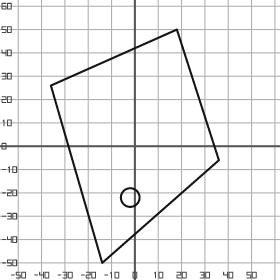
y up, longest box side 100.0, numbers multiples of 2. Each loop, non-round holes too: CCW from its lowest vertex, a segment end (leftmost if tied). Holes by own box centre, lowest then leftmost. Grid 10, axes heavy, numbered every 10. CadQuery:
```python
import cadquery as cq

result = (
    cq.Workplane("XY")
    .moveTo(-14.0, -50.0)
    .lineTo(36.0, -6.0)
    .lineTo(18.0, 50.0)
    .lineTo(-36.0, 26.0)
    .close()
    .moveTo(-2.0, -22.0)
    .circle(4.0)
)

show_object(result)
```